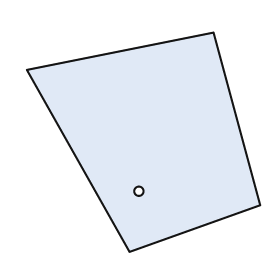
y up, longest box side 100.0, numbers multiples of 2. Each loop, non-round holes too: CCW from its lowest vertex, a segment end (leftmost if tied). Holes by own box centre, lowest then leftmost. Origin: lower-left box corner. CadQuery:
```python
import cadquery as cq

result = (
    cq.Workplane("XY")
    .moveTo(44.0, 0.0)
    .lineTo(100.0, 20.0)
    .lineTo(80.0, 94.0)
    .lineTo(0.0, 78.0)
    .close()
    .moveTo(48.0, 26.0)
    .circle(2.0)
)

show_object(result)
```